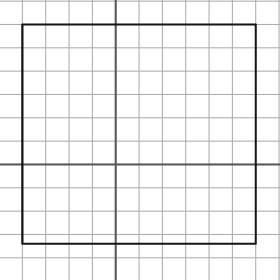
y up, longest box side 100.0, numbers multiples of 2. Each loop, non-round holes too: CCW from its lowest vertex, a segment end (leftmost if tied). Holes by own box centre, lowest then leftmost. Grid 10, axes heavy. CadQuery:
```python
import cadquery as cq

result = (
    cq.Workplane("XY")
    .moveTo(-40.0, -34.0)
    .lineTo(60.0, -34.0)
    .lineTo(60.0, 60.0)
    .lineTo(-40.0, 60.0)
    .close()
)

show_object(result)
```